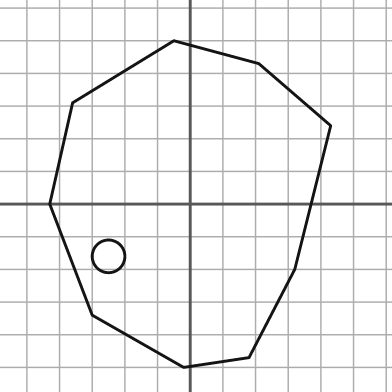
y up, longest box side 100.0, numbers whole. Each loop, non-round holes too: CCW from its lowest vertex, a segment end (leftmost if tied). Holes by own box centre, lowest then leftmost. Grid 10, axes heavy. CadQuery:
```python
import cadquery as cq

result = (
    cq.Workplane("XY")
    .moveTo(-2.0, -50.0)
    .lineTo(18.0, -47.0)
    .lineTo(32.0, -20.0)
    .lineTo(43.0, 24.0)
    .lineTo(21.0, 43.0)
    .lineTo(-5.0, 50.0)
    .lineTo(-36.0, 31.0)
    .lineTo(-43.0, 0.0)
    .lineTo(-30.0, -34.0)
    .close()
    .moveTo(-25.0, -16.0)
    .circle(5.0)
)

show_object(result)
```